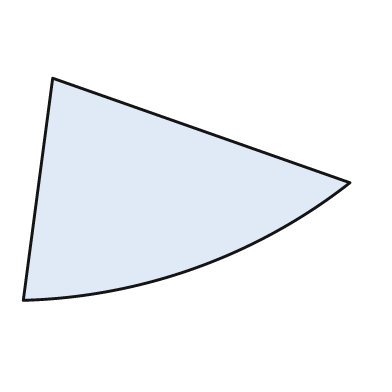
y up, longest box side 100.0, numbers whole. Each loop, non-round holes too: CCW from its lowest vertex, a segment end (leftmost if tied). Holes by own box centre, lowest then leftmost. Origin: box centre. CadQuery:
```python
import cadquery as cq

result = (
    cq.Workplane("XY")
    .moveTo(-50.0, -34.0)
    .threePointArc((3.0, -24.0), (50.0, 2.0))
    .lineTo(-41.0, 34.0)
    .close()
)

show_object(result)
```